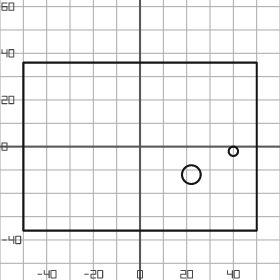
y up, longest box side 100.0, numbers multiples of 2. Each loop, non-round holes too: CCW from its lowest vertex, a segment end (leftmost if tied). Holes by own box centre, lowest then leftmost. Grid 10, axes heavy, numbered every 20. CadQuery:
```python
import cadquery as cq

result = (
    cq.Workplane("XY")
    .moveTo(-50.0, -36.0)
    .lineTo(50.0, -36.0)
    .lineTo(50.0, 36.0)
    .lineTo(-50.0, 36.0)
    .close()
    .moveTo(22.0, -12.0)
    .circle(4.0)
    .moveTo(40.0, -2.0)
    .circle(2.0)
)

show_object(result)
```